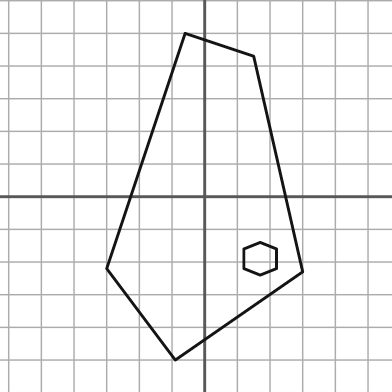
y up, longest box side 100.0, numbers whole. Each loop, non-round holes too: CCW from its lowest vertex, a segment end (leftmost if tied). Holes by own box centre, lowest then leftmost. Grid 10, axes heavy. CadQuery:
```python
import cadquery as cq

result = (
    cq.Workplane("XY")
    .moveTo(-9.0, -50.0)
    .lineTo(30.0, -23.0)
    .lineTo(15.0, 43.0)
    .lineTo(-6.0, 50.0)
    .lineTo(-30.0, -22.0)
    .close()
    .moveTo(17.0, -24.0)
    .lineTo(22.0, -22.0)
    .lineTo(22.0, -16.0)
    .lineTo(17.0, -14.0)
    .lineTo(12.0, -16.0)
    .lineTo(12.0, -22.0)
    .close()
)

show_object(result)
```